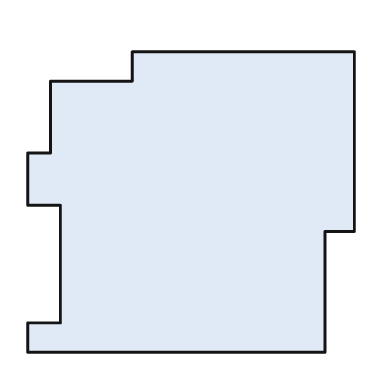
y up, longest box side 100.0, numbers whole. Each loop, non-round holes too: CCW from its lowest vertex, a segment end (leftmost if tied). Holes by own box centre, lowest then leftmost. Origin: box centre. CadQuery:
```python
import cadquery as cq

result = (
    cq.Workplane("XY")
    .moveTo(-50.0, -46.0)
    .lineTo(41.0, -46.0)
    .lineTo(41.0, -9.0)
    .lineTo(50.0, -9.0)
    .lineTo(50.0, 46.0)
    .lineTo(-18.0, 46.0)
    .lineTo(-18.0, 37.0)
    .lineTo(-43.0, 37.0)
    .lineTo(-43.0, 15.0)
    .lineTo(-50.0, 15.0)
    .lineTo(-50.0, -1.0)
    .lineTo(-40.0, -1.0)
    .lineTo(-40.0, -37.0)
    .lineTo(-50.0, -37.0)
    .close()
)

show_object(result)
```